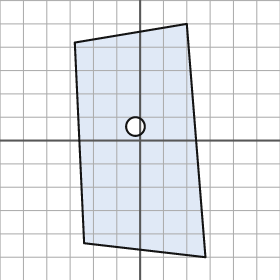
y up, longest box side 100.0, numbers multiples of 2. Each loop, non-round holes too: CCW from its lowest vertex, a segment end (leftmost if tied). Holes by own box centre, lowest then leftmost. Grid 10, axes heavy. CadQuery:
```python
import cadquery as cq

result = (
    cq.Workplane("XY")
    .moveTo(28.0, -50.0)
    .lineTo(20.0, 50.0)
    .lineTo(-28.0, 42.0)
    .lineTo(-24.0, -44.0)
    .close()
    .moveTo(-2.0, 6.0)
    .circle(4.0)
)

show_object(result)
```